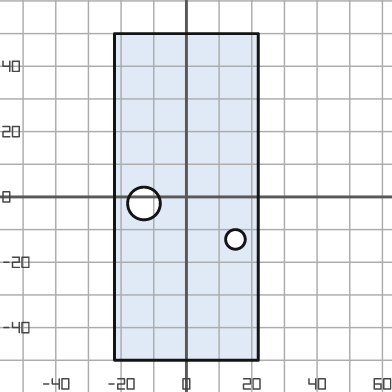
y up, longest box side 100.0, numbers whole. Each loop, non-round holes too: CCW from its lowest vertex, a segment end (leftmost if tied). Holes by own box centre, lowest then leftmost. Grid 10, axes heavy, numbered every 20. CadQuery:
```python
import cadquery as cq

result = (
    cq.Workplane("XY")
    .moveTo(-22.0, -50.0)
    .lineTo(22.0, -50.0)
    .lineTo(22.0, 50.0)
    .lineTo(-22.0, 50.0)
    .close()
    .moveTo(15.0, -13.0)
    .circle(3.0)
    .moveTo(-13.0, -2.0)
    .circle(5.0)
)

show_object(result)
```